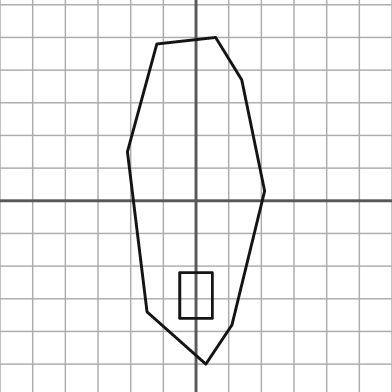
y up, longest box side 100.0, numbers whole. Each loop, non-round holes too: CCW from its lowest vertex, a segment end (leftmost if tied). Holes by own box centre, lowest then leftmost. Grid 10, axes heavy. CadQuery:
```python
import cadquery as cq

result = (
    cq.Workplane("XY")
    .moveTo(3.0, -50.0)
    .lineTo(11.0, -38.0)
    .lineTo(21.0, 3.0)
    .lineTo(14.0, 37.0)
    .lineTo(6.0, 50.0)
    .lineTo(-12.0, 48.0)
    .lineTo(-21.0, 15.0)
    .lineTo(-15.0, -34.0)
    .close()
    .moveTo(-5.0, -36.0)
    .lineTo(5.0, -36.0)
    .lineTo(5.0, -22.0)
    .lineTo(-5.0, -22.0)
    .close()
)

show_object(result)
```